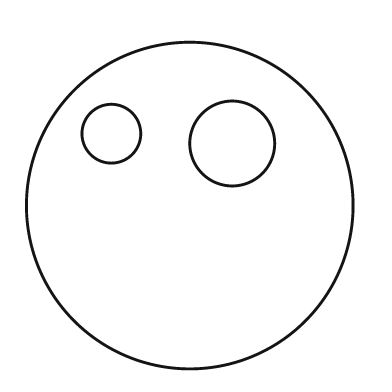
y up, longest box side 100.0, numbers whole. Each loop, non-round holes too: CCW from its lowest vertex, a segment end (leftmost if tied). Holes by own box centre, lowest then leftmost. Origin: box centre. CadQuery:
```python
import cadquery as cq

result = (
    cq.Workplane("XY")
    .moveTo(0.0, 0.0)
    .circle(50.0)
    .moveTo(13.0, 19.0)
    .circle(13.0)
    .moveTo(-24.0, 22.0)
    .circle(9.0)
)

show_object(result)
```